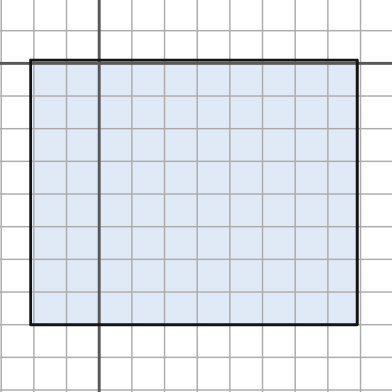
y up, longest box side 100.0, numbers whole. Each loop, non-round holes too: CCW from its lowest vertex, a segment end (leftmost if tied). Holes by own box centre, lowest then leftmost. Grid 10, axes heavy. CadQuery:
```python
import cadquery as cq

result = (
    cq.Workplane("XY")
    .moveTo(-21.0, -80.0)
    .lineTo(79.0, -80.0)
    .lineTo(79.0, 1.0)
    .lineTo(-21.0, 1.0)
    .close()
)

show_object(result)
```